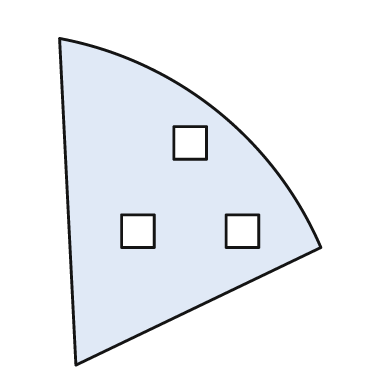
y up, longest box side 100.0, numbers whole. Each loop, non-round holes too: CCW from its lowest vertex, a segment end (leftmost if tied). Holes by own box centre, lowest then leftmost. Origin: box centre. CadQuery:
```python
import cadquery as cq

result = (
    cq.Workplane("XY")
    .moveTo(-35.0, -50.0)
    .lineTo(40.0, -14.0)
    .threePointArc((8.0, 28.0), (-40.0, 50.0))
    .close()
    .moveTo(-21.0, -14.0)
    .lineTo(-11.0, -14.0)
    .lineTo(-11.0, -4.0)
    .lineTo(-21.0, -4.0)
    .close()
    .moveTo(11.0, -14.0)
    .lineTo(21.0, -14.0)
    .lineTo(21.0, -4.0)
    .lineTo(11.0, -4.0)
    .close()
    .moveTo(-5.0, 13.0)
    .lineTo(5.0, 13.0)
    .lineTo(5.0, 23.0)
    .lineTo(-5.0, 23.0)
    .close()
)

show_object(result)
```